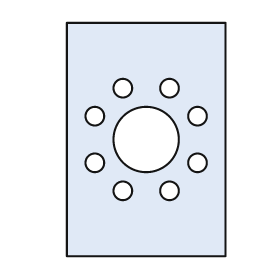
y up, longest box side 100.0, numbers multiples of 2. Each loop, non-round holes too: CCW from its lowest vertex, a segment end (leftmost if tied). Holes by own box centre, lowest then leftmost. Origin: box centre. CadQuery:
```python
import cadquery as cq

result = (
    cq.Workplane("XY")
    .moveTo(-34.0, -50.0)
    .lineTo(34.0, -50.0)
    .lineTo(34.0, 50.0)
    .lineTo(-34.0, 50.0)
    .close()
    .moveTo(-10.0, -22.0)
    .circle(4.0)
    .moveTo(10.0, -22.0)
    .circle(4.0)
    .moveTo(-22.0, -10.0)
    .circle(4.0)
    .moveTo(22.0, -10.0)
    .circle(4.0)
    .moveTo(0.0, 0.0)
    .circle(14.0)
    .moveTo(-22.0, 10.0)
    .circle(4.0)
    .moveTo(22.0, 10.0)
    .circle(4.0)
    .moveTo(-10.0, 22.0)
    .circle(4.0)
    .moveTo(10.0, 22.0)
    .circle(4.0)
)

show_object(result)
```